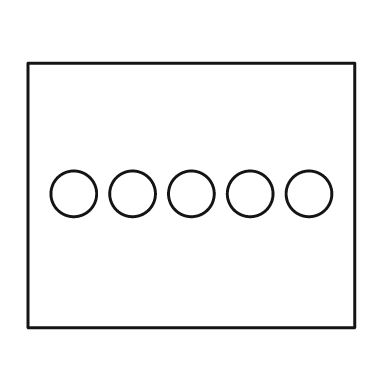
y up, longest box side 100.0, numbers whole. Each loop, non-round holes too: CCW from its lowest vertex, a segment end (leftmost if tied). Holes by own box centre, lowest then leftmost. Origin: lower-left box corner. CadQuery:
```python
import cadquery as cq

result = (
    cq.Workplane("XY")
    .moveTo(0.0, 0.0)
    .lineTo(100.0, 0.0)
    .lineTo(100.0, 81.0)
    .lineTo(0.0, 81.0)
    .close()
    .moveTo(14.0, 41.0)
    .circle(7.0)
    .moveTo(32.0, 41.0)
    .circle(7.0)
    .moveTo(50.0, 41.0)
    .circle(7.0)
    .moveTo(68.0, 41.0)
    .circle(7.0)
    .moveTo(86.0, 41.0)
    .circle(7.0)
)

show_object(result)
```